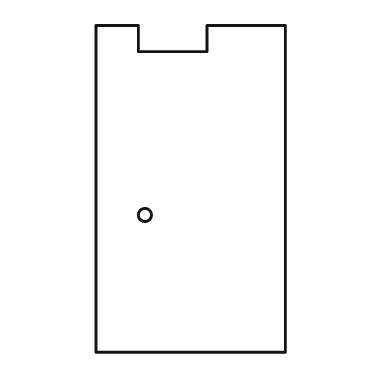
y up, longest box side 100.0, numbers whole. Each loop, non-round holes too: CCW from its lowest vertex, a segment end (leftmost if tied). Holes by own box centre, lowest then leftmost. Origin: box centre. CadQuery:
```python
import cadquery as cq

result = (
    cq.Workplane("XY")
    .moveTo(-29.0, -50.0)
    .lineTo(29.0, -50.0)
    .lineTo(29.0, 50.0)
    .lineTo(5.0, 50.0)
    .lineTo(5.0, 42.0)
    .lineTo(-16.0, 42.0)
    .lineTo(-16.0, 50.0)
    .lineTo(-29.0, 50.0)
    .close()
    .moveTo(-14.0, -8.0)
    .circle(2.0)
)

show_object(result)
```